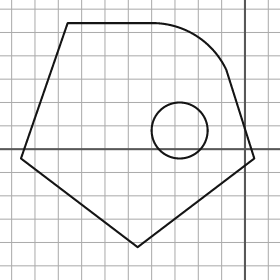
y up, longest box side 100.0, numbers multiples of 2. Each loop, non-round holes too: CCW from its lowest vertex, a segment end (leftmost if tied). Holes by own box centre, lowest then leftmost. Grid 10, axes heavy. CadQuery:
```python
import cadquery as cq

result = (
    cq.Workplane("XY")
    .moveTo(-46.0, -42.0)
    .lineTo(4.0, -4.0)
    .lineTo(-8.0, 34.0)
    .threePointArc((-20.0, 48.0), (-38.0, 54.0))
    .lineTo(-76.0, 54.0)
    .lineTo(-96.0, -4.0)
    .close()
    .moveTo(-28.0, 8.0)
    .circle(12.0)
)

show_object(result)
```